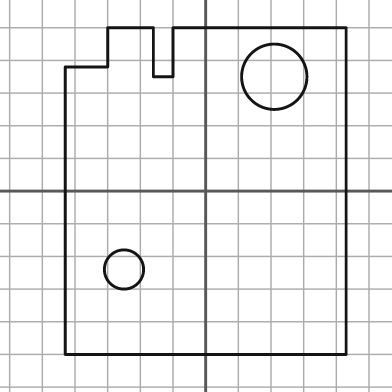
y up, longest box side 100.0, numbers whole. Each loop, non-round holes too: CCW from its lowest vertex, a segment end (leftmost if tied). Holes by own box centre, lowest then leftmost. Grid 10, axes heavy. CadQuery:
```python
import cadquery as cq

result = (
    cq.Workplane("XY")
    .moveTo(-43.0, -50.0)
    .lineTo(43.0, -50.0)
    .lineTo(43.0, 50.0)
    .lineTo(-10.0, 50.0)
    .lineTo(-10.0, 35.0)
    .lineTo(-16.0, 35.0)
    .lineTo(-16.0, 50.0)
    .lineTo(-30.0, 50.0)
    .lineTo(-30.0, 38.0)
    .lineTo(-43.0, 38.0)
    .close()
    .moveTo(-25.0, -24.0)
    .circle(6.0)
    .moveTo(21.0, 35.0)
    .circle(10.0)
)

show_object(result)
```